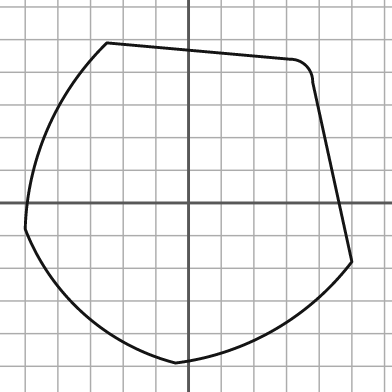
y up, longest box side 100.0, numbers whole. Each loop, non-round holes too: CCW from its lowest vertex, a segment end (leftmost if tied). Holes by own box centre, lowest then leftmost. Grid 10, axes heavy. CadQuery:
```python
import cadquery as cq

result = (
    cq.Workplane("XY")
    .moveTo(-4.0, -49.0)
    .threePointArc((26.0, -39.0), (50.0, -18.0))
    .lineTo(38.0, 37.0)
    .threePointArc((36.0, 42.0), (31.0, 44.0))
    .lineTo(-25.0, 49.0)
    .threePointArc((-43.0, 23.0), (-50.0, -8.0))
    .threePointArc((-32.0, -34.0), (-4.0, -49.0))
    .close()
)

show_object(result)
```